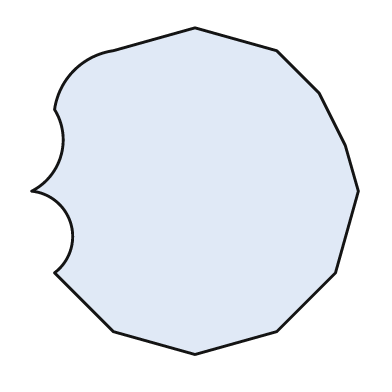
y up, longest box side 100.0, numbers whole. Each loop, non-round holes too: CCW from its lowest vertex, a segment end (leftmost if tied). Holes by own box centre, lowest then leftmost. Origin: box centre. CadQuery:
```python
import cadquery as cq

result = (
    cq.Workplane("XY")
    .moveTo(0.0, -50.0)
    .lineTo(25.0, -43.0)
    .lineTo(43.0, -25.0)
    .lineTo(50.0, 0.0)
    .lineTo(46.0, 14.0)
    .lineTo(38.0, 30.0)
    .lineTo(25.0, 43.0)
    .lineTo(0.0, 50.0)
    .lineTo(-25.0, 43.0)
    .threePointArc((-37.0, 37.0), (-43.0, 25.0))
    .threePointArc((-41.0, 11.0), (-50.0, 0.0))
    .threePointArc((-38.0, -10.0), (-43.0, -25.0))
    .lineTo(-25.0, -43.0)
    .close()
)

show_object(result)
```